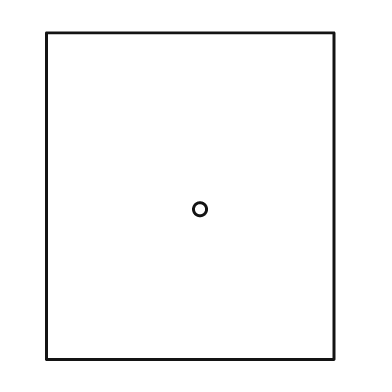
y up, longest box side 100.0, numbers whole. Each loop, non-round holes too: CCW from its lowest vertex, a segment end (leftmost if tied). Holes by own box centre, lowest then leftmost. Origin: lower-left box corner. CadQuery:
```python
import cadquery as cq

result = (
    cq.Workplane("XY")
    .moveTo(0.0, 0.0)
    .lineTo(88.0, 0.0)
    .lineTo(88.0, 100.0)
    .lineTo(0.0, 100.0)
    .close()
    .moveTo(47.0, 46.0)
    .circle(2.0)
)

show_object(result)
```